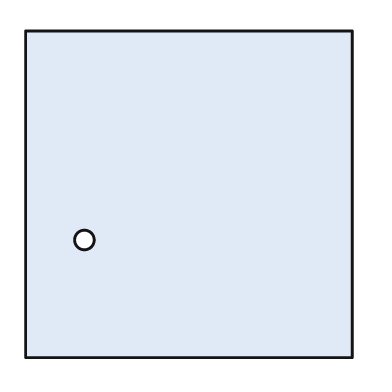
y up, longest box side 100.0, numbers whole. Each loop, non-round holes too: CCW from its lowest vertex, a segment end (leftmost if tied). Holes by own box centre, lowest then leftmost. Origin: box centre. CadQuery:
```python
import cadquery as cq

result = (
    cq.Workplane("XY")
    .moveTo(-50.0, -50.0)
    .lineTo(50.0, -50.0)
    .lineTo(50.0, 50.0)
    .lineTo(-50.0, 50.0)
    .close()
    .moveTo(-32.0, -14.0)
    .circle(3.0)
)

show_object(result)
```